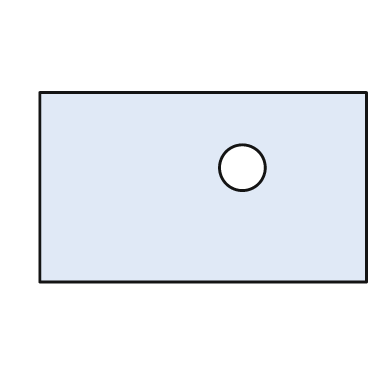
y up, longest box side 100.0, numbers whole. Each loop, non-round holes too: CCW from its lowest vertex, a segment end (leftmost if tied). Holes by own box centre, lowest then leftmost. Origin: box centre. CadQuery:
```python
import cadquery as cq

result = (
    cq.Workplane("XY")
    .moveTo(-50.0, -29.0)
    .lineTo(50.0, -29.0)
    .lineTo(50.0, 29.0)
    .lineTo(-50.0, 29.0)
    .close()
    .moveTo(12.0, 6.0)
    .circle(7.0)
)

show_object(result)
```